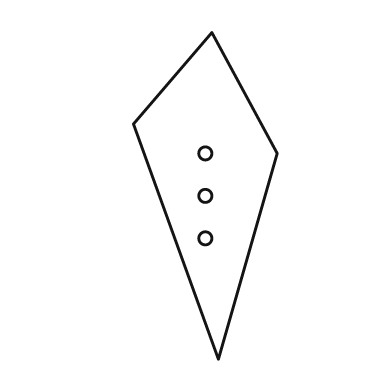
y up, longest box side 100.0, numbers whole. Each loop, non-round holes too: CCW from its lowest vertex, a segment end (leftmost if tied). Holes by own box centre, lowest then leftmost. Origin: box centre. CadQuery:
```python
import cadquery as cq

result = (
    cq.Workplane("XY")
    .moveTo(4.0, -50.0)
    .lineTo(22.0, 13.0)
    .lineTo(2.0, 50.0)
    .lineTo(-22.0, 22.0)
    .close()
    .moveTo(0.0, -13.0)
    .circle(2.0)
    .moveTo(0.0, 0.0)
    .circle(2.0)
    .moveTo(0.0, 13.0)
    .circle(2.0)
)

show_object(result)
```